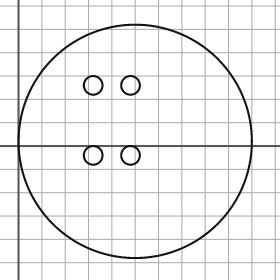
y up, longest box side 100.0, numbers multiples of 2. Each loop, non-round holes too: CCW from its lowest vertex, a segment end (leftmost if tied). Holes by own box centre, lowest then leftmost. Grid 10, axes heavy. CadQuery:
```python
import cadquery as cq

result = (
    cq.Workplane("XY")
    .moveTo(50.0, 2.0)
    .circle(50.0)
    .moveTo(32.0, -4.0)
    .circle(4.0)
    .moveTo(48.0, -4.0)
    .circle(4.0)
    .moveTo(32.0, 26.0)
    .circle(4.0)
    .moveTo(48.0, 26.0)
    .circle(4.0)
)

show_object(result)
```